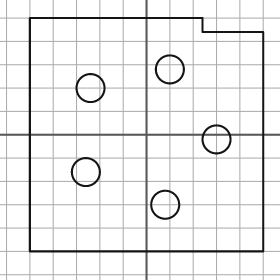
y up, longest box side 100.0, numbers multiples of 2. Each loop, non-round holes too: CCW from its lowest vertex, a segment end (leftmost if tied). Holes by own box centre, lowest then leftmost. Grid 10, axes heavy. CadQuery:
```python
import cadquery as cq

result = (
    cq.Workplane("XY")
    .moveTo(-50.0, -50.0)
    .lineTo(50.0, -50.0)
    .lineTo(50.0, 44.0)
    .lineTo(24.0, 44.0)
    .lineTo(24.0, 50.0)
    .lineTo(-50.0, 50.0)
    .close()
    .moveTo(8.0, -30.0)
    .circle(6.0)
    .moveTo(-26.0, -16.0)
    .circle(6.0)
    .moveTo(30.0, -2.0)
    .circle(6.0)
    .moveTo(-24.0, 20.0)
    .circle(6.0)
    .moveTo(10.0, 28.0)
    .circle(6.0)
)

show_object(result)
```